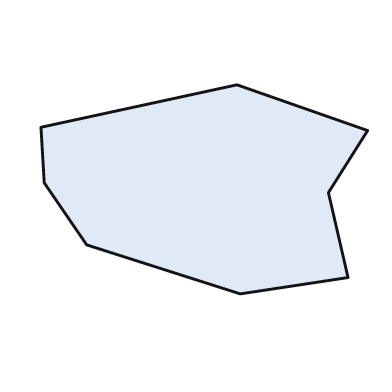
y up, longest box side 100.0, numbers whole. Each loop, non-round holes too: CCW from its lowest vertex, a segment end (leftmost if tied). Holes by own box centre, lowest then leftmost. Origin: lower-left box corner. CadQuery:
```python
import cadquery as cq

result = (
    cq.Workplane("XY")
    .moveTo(61.0, 0.0)
    .lineTo(94.0, 5.0)
    .lineTo(88.0, 31.0)
    .lineTo(100.0, 50.0)
    .lineTo(60.0, 64.0)
    .lineTo(0.0, 51.0)
    .lineTo(1.0, 34.0)
    .lineTo(14.0, 15.0)
    .close()
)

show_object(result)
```